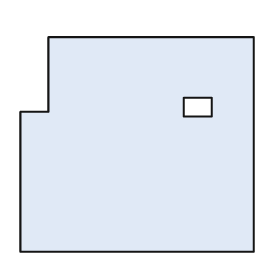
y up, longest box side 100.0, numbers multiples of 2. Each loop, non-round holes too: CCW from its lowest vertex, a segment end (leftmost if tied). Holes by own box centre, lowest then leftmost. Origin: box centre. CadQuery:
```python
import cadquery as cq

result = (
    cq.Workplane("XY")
    .moveTo(-50.0, -46.0)
    .lineTo(50.0, -46.0)
    .lineTo(50.0, 46.0)
    .lineTo(-38.0, 46.0)
    .lineTo(-38.0, 14.0)
    .lineTo(-50.0, 14.0)
    .close()
    .moveTo(20.0, 12.0)
    .lineTo(32.0, 12.0)
    .lineTo(32.0, 20.0)
    .lineTo(20.0, 20.0)
    .close()
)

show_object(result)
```